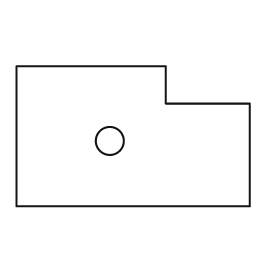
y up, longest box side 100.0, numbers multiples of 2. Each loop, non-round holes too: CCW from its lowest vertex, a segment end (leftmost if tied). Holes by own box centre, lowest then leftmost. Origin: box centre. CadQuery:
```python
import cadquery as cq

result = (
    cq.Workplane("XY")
    .moveTo(-50.0, -30.0)
    .lineTo(50.0, -30.0)
    .lineTo(50.0, 14.0)
    .lineTo(14.0, 14.0)
    .lineTo(14.0, 30.0)
    .lineTo(-50.0, 30.0)
    .close()
    .moveTo(-10.0, -2.0)
    .circle(6.0)
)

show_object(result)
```